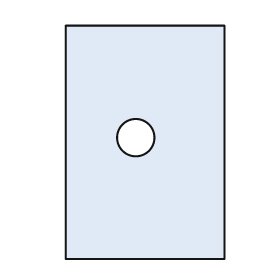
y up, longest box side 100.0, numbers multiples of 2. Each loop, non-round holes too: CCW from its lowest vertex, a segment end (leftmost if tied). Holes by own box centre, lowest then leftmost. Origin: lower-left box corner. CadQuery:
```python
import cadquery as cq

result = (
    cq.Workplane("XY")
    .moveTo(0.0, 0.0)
    .lineTo(68.0, 0.0)
    .lineTo(68.0, 100.0)
    .lineTo(0.0, 100.0)
    .close()
    .moveTo(30.0, 52.0)
    .circle(8.0)
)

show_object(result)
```